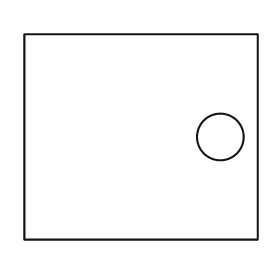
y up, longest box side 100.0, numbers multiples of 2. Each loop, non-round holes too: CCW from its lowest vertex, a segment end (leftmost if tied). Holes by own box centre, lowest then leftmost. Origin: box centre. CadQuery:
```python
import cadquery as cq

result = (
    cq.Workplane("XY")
    .moveTo(-50.0, -44.0)
    .lineTo(50.0, -44.0)
    .lineTo(50.0, 44.0)
    .lineTo(-50.0, 44.0)
    .close()
    .moveTo(34.0, 0.0)
    .circle(10.0)
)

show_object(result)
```